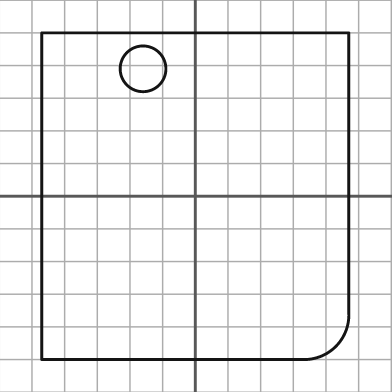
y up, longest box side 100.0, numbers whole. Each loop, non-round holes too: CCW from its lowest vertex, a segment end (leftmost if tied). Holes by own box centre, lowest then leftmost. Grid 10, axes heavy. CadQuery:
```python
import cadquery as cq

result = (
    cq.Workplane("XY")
    .moveTo(-47.0, -50.0)
    .lineTo(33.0, -50.0)
    .threePointArc((43.0, -46.0), (47.0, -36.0))
    .lineTo(47.0, 50.0)
    .lineTo(-47.0, 50.0)
    .close()
    .moveTo(-16.0, 39.0)
    .circle(7.0)
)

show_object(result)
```